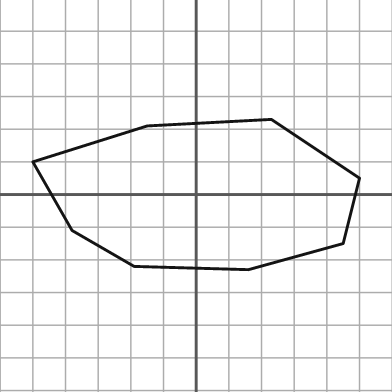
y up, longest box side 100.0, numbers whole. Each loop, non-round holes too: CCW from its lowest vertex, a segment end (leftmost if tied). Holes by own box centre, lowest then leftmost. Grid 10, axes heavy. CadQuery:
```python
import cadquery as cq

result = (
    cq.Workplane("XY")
    .moveTo(16.0, -23.0)
    .lineTo(45.0, -15.0)
    .lineTo(50.0, 5.0)
    .lineTo(23.0, 23.0)
    .lineTo(-15.0, 21.0)
    .lineTo(-50.0, 10.0)
    .lineTo(-38.0, -11.0)
    .lineTo(-19.0, -22.0)
    .close()
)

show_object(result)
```